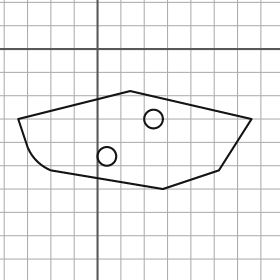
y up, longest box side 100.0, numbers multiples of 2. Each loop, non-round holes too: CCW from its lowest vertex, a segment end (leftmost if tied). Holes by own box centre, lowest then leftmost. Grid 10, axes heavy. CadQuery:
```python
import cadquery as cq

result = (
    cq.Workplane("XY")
    .moveTo(28.0, -60.0)
    .lineTo(52.0, -52.0)
    .lineTo(66.0, -30.0)
    .lineTo(14.0, -18.0)
    .lineTo(-34.0, -30.0)
    .lineTo(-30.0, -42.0)
    .threePointArc((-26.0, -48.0), (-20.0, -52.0))
    .close()
    .moveTo(4.0, -46.0)
    .circle(4.0)
    .moveTo(24.0, -30.0)
    .circle(4.0)
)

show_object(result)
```